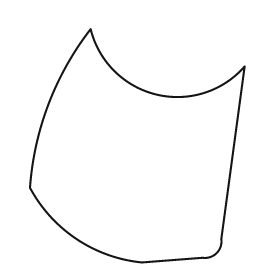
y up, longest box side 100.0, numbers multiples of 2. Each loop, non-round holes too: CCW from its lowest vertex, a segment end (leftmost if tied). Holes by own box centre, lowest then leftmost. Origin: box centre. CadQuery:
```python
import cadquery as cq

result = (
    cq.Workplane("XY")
    .moveTo(2.0, -50.0)
    .lineTo(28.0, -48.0)
    .threePointArc((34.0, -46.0), (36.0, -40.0))
    .lineTo(46.0, 34.0)
    .threePointArc((8.0, 22.0), (-20.0, 50.0))
    .threePointArc((-38.0, 18.0), (-46.0, -18.0))
    .threePointArc((-26.0, -40.0), (2.0, -50.0))
    .close()
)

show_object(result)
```